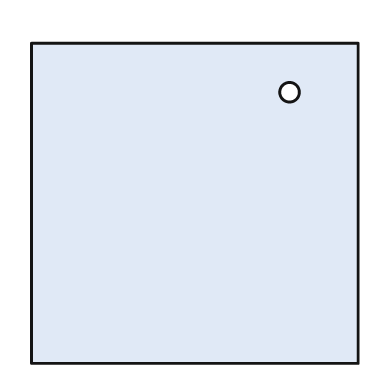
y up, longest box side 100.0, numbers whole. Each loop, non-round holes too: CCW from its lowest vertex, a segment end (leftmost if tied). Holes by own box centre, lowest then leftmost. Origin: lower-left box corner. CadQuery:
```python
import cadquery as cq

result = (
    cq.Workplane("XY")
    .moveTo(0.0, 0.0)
    .lineTo(100.0, 0.0)
    .lineTo(100.0, 98.0)
    .lineTo(0.0, 98.0)
    .close()
    .moveTo(79.0, 83.0)
    .circle(3.0)
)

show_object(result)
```